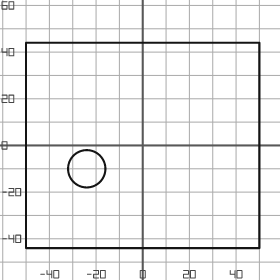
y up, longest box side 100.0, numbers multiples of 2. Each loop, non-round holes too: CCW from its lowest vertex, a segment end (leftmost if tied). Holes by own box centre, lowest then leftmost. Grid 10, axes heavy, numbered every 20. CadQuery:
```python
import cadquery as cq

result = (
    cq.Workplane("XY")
    .moveTo(-50.0, -44.0)
    .lineTo(50.0, -44.0)
    .lineTo(50.0, 44.0)
    .lineTo(-50.0, 44.0)
    .close()
    .moveTo(-24.0, -10.0)
    .circle(8.0)
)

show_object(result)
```